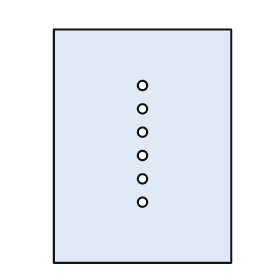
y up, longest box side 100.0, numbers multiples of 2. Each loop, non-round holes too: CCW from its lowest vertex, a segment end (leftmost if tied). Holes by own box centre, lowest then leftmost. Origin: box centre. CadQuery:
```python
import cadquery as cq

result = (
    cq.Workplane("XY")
    .moveTo(-38.0, -50.0)
    .lineTo(38.0, -50.0)
    .lineTo(38.0, 50.0)
    .lineTo(-38.0, 50.0)
    .close()
    .moveTo(0.0, -24.0)
    .circle(2.0)
    .moveTo(0.0, -14.0)
    .circle(2.0)
    .moveTo(0.0, -4.0)
    .circle(2.0)
    .moveTo(0.0, 6.0)
    .circle(2.0)
    .moveTo(0.0, 16.0)
    .circle(2.0)
    .moveTo(0.0, 26.0)
    .circle(2.0)
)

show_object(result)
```